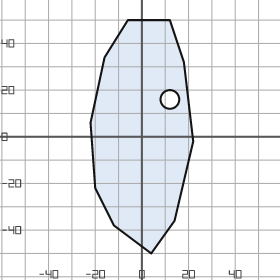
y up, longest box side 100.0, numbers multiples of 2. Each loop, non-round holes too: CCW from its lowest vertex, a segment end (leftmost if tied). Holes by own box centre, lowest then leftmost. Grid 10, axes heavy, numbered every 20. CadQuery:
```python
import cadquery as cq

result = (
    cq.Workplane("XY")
    .moveTo(4.0, -50.0)
    .lineTo(14.0, -36.0)
    .lineTo(22.0, -2.0)
    .lineTo(18.0, 32.0)
    .lineTo(12.0, 50.0)
    .lineTo(-6.0, 50.0)
    .lineTo(-16.0, 34.0)
    .lineTo(-22.0, 6.0)
    .lineTo(-20.0, -22.0)
    .lineTo(-12.0, -38.0)
    .close()
    .moveTo(12.0, 16.0)
    .circle(4.0)
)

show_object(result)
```